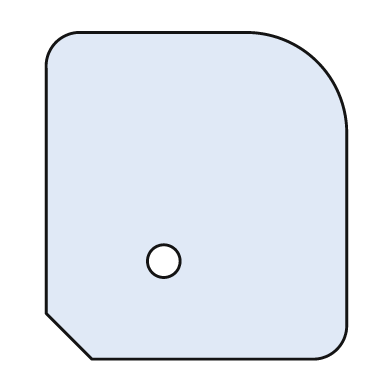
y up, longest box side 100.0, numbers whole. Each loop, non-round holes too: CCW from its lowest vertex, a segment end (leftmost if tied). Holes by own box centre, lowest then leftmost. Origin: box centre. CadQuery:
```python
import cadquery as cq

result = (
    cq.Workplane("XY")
    .moveTo(-32.0, -50.0)
    .lineTo(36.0, -50.0)
    .threePointArc((43.0, -47.0), (46.0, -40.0))
    .lineTo(46.0, 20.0)
    .threePointArc((37.0, 41.0), (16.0, 50.0))
    .lineTo(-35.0, 50.0)
    .threePointArc((-43.0, 47.0), (-46.0, 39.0))
    .lineTo(-46.0, -36.0)
    .close()
    .moveTo(-10.0, -20.0)
    .circle(5.0)
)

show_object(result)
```